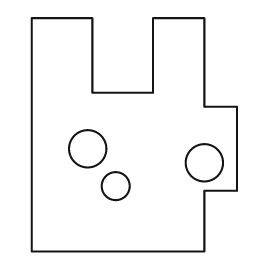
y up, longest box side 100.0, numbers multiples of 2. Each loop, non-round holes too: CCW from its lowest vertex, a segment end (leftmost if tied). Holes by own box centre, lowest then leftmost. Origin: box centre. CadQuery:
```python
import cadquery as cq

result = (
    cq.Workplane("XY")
    .moveTo(-44.0, -50.0)
    .lineTo(30.0, -50.0)
    .lineTo(30.0, -24.0)
    .lineTo(44.0, -24.0)
    .lineTo(44.0, 12.0)
    .lineTo(30.0, 12.0)
    .lineTo(30.0, 50.0)
    .lineTo(8.0, 50.0)
    .lineTo(8.0, 18.0)
    .lineTo(-18.0, 18.0)
    .lineTo(-18.0, 50.0)
    .lineTo(-44.0, 50.0)
    .close()
    .moveTo(-8.0, -22.0)
    .circle(6.0)
    .moveTo(30.0, -12.0)
    .circle(8.0)
    .moveTo(-20.0, -6.0)
    .circle(8.0)
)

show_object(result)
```